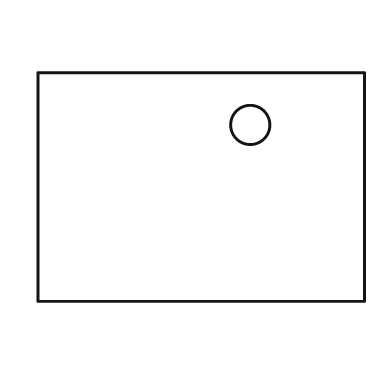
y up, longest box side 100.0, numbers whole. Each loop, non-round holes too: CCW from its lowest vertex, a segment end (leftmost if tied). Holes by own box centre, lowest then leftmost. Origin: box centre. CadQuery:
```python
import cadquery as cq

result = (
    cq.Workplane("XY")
    .moveTo(-50.0, -35.0)
    .lineTo(50.0, -35.0)
    .lineTo(50.0, 35.0)
    .lineTo(-50.0, 35.0)
    .close()
    .moveTo(15.0, 19.0)
    .circle(6.0)
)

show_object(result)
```